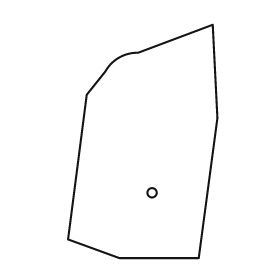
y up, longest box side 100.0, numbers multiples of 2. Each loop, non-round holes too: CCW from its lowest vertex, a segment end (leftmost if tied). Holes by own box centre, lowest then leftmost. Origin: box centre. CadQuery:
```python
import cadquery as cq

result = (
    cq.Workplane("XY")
    .moveTo(-10.0, -50.0)
    .lineTo(24.0, -50.0)
    .lineTo(32.0, 10.0)
    .lineTo(30.0, 50.0)
    .lineTo(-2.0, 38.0)
    .threePointArc((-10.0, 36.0), (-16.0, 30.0))
    .lineTo(-24.0, 20.0)
    .lineTo(-32.0, -42.0)
    .close()
    .moveTo(4.0, -22.0)
    .circle(2.0)
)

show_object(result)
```